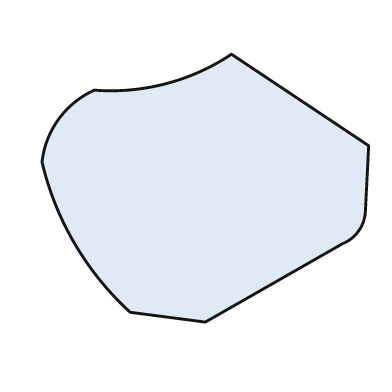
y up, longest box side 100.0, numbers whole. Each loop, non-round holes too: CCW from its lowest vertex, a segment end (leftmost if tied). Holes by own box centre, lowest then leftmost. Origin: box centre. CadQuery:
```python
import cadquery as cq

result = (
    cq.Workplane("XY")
    .moveTo(0.0, -41.0)
    .lineTo(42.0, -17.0)
    .threePointArc((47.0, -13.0), (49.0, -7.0))
    .lineTo(50.0, 13.0)
    .lineTo(8.0, 41.0)
    .threePointArc((-12.0, 32.0), (-34.0, 30.0))
    .threePointArc((-45.0, 21.0), (-50.0, 8.0))
    .threePointArc((-40.0, -17.0), (-23.0, -38.0))
    .close()
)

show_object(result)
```